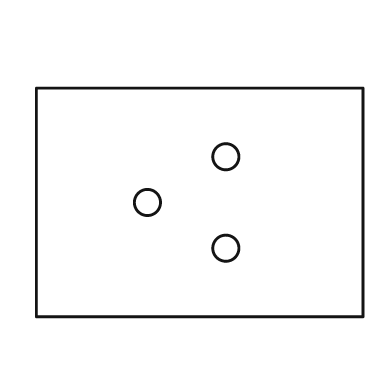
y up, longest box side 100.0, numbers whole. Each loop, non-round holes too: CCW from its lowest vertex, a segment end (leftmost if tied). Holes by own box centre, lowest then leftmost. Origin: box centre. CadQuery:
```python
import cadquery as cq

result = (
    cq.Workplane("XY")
    .moveTo(-50.0, -35.0)
    .lineTo(50.0, -35.0)
    .lineTo(50.0, 35.0)
    .lineTo(-50.0, 35.0)
    .close()
    .moveTo(8.0, -14.0)
    .circle(4.0)
    .moveTo(-16.0, 0.0)
    .circle(4.0)
    .moveTo(8.0, 14.0)
    .circle(4.0)
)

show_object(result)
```